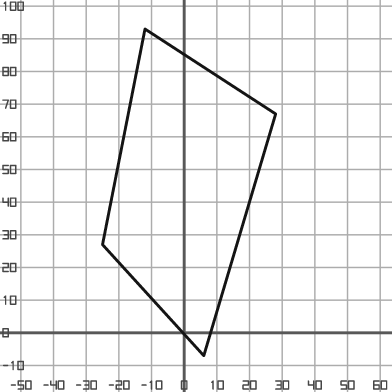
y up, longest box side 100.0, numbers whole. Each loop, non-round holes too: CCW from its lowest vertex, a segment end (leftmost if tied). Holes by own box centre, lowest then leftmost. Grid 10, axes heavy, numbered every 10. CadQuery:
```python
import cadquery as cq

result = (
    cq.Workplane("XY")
    .moveTo(6.0, -7.0)
    .lineTo(28.0, 67.0)
    .lineTo(-12.0, 93.0)
    .lineTo(-25.0, 27.0)
    .close()
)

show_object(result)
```